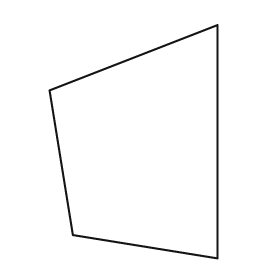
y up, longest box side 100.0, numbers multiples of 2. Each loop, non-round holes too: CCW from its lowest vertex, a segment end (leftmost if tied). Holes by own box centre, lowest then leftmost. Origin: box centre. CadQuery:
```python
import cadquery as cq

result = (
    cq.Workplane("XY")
    .moveTo(36.0, -50.0)
    .lineTo(36.0, 50.0)
    .lineTo(-36.0, 22.0)
    .lineTo(-26.0, -40.0)
    .close()
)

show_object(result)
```